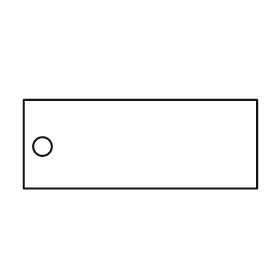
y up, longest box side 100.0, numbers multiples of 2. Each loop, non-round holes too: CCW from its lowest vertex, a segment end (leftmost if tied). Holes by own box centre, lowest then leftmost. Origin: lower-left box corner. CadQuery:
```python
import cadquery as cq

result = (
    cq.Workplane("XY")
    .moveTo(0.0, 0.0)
    .lineTo(100.0, 0.0)
    .lineTo(100.0, 38.0)
    .lineTo(0.0, 38.0)
    .close()
    .moveTo(8.0, 18.0)
    .circle(4.0)
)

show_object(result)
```